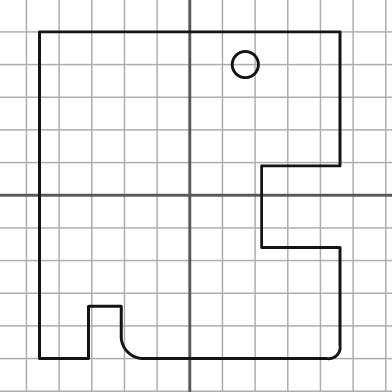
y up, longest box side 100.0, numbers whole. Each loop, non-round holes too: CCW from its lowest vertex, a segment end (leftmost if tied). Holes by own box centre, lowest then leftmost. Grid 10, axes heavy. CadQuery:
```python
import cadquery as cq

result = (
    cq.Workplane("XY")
    .moveTo(-46.0, -50.0)
    .lineTo(-31.0, -50.0)
    .lineTo(-31.0, -34.0)
    .lineTo(-21.0, -34.0)
    .lineTo(-21.0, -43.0)
    .threePointArc((-19.0, -48.0), (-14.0, -50.0))
    .lineTo(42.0, -50.0)
    .threePointArc((45.0, -49.0), (46.0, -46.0))
    .lineTo(46.0, -16.0)
    .lineTo(22.0, -16.0)
    .lineTo(22.0, 9.0)
    .lineTo(46.0, 9.0)
    .lineTo(46.0, 50.0)
    .lineTo(-46.0, 50.0)
    .close()
    .moveTo(17.0, 40.0)
    .circle(4.0)
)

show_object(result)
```